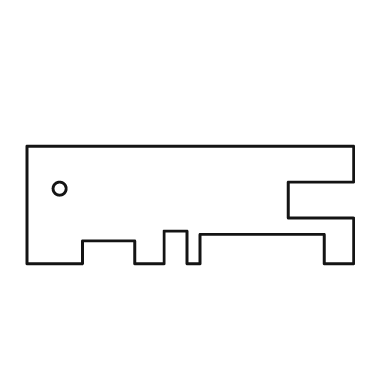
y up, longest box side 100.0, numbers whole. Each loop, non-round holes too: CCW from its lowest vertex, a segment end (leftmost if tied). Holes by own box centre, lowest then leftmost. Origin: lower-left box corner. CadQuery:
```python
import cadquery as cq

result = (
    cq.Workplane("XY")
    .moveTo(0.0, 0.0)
    .lineTo(17.0, 0.0)
    .lineTo(17.0, 7.0)
    .lineTo(33.0, 7.0)
    .lineTo(33.0, 0.0)
    .lineTo(42.0, 0.0)
    .lineTo(42.0, 10.0)
    .lineTo(49.0, 10.0)
    .lineTo(49.0, 0.0)
    .lineTo(53.0, 0.0)
    .lineTo(53.0, 9.0)
    .lineTo(91.0, 9.0)
    .lineTo(91.0, 0.0)
    .lineTo(100.0, 0.0)
    .lineTo(100.0, 14.0)
    .lineTo(80.0, 14.0)
    .lineTo(80.0, 25.0)
    .lineTo(100.0, 25.0)
    .lineTo(100.0, 36.0)
    .lineTo(0.0, 36.0)
    .close()
    .moveTo(10.0, 23.0)
    .circle(2.0)
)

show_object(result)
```